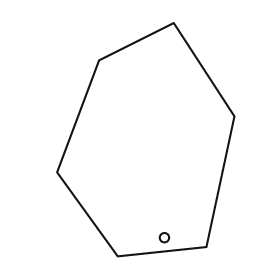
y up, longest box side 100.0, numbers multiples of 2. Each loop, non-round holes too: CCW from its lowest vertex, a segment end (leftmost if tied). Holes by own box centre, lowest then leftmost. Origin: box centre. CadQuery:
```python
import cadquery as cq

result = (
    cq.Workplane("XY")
    .moveTo(-12.0, -50.0)
    .lineTo(26.0, -46.0)
    .lineTo(38.0, 10.0)
    .lineTo(12.0, 50.0)
    .lineTo(-20.0, 34.0)
    .lineTo(-38.0, -14.0)
    .close()
    .moveTo(8.0, -42.0)
    .circle(2.0)
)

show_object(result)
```